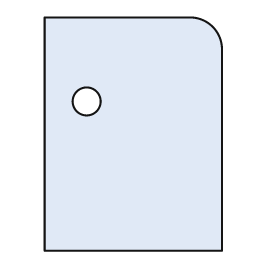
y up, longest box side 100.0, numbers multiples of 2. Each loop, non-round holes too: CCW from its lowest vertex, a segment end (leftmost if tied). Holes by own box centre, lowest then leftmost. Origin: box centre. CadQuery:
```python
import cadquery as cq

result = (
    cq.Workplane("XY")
    .moveTo(-38.0, -50.0)
    .lineTo(38.0, -50.0)
    .lineTo(38.0, 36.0)
    .threePointArc((34.0, 46.0), (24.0, 50.0))
    .lineTo(-38.0, 50.0)
    .close()
    .moveTo(-20.0, 14.0)
    .circle(6.0)
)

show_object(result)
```